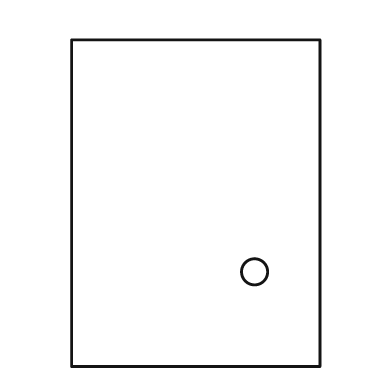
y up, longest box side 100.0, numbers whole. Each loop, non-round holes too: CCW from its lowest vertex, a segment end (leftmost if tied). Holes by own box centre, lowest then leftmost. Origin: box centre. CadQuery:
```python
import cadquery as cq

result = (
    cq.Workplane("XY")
    .moveTo(-38.0, -50.0)
    .lineTo(38.0, -50.0)
    .lineTo(38.0, 50.0)
    .lineTo(-38.0, 50.0)
    .close()
    .moveTo(18.0, -21.0)
    .circle(4.0)
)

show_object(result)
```